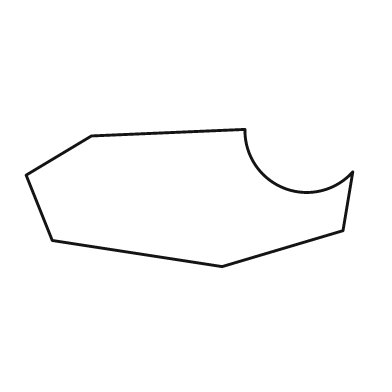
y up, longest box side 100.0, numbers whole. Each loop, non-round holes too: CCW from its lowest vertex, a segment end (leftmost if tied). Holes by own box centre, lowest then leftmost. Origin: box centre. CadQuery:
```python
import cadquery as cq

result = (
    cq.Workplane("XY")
    .moveTo(10.0, -21.0)
    .lineTo(47.0, -10.0)
    .lineTo(50.0, 8.0)
    .threePointArc((29.0, 3.0), (17.0, 21.0))
    .lineTo(-30.0, 19.0)
    .lineTo(-50.0, 7.0)
    .lineTo(-42.0, -13.0)
    .close()
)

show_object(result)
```